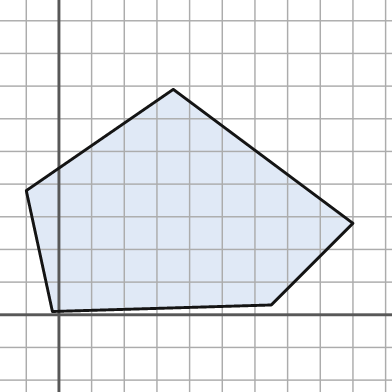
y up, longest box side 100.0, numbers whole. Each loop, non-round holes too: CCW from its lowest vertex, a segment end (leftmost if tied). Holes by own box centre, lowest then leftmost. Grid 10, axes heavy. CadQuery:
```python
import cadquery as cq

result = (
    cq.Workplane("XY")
    .moveTo(-2.0, 1.0)
    .lineTo(65.0, 3.0)
    .lineTo(90.0, 28.0)
    .lineTo(35.0, 69.0)
    .lineTo(-10.0, 38.0)
    .close()
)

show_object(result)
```